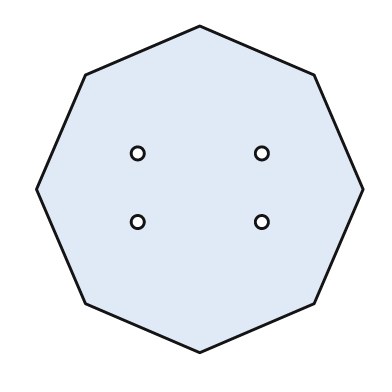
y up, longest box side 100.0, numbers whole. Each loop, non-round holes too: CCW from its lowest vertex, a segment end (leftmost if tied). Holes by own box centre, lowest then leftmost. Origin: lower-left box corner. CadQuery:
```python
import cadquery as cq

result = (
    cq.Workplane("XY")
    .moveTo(50.0, 0.0)
    .lineTo(85.0, 15.0)
    .lineTo(100.0, 50.0)
    .lineTo(85.0, 85.0)
    .lineTo(50.0, 100.0)
    .lineTo(15.0, 85.0)
    .lineTo(0.0, 50.0)
    .lineTo(15.0, 15.0)
    .close()
    .moveTo(31.0, 40.0)
    .circle(2.0)
    .moveTo(69.0, 40.0)
    .circle(2.0)
    .moveTo(31.0, 61.0)
    .circle(2.0)
    .moveTo(69.0, 61.0)
    .circle(2.0)
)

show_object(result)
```